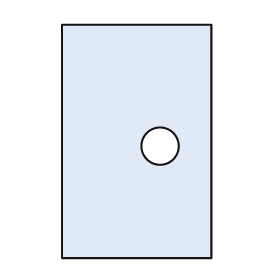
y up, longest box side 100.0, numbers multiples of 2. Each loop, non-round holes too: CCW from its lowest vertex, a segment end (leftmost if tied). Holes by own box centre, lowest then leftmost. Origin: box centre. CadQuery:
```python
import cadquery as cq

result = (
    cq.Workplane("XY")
    .moveTo(-32.0, -50.0)
    .lineTo(32.0, -50.0)
    .lineTo(32.0, 50.0)
    .lineTo(-32.0, 50.0)
    .close()
    .moveTo(10.0, -2.0)
    .circle(8.0)
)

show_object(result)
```